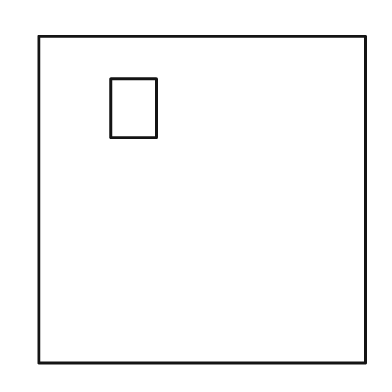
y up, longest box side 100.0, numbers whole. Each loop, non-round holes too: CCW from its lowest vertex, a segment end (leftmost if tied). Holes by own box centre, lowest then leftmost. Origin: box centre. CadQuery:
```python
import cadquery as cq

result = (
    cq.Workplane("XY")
    .moveTo(-50.0, -50.0)
    .lineTo(50.0, -50.0)
    .lineTo(50.0, 50.0)
    .lineTo(-50.0, 50.0)
    .close()
    .moveTo(-28.0, 19.0)
    .lineTo(-14.0, 19.0)
    .lineTo(-14.0, 37.0)
    .lineTo(-28.0, 37.0)
    .close()
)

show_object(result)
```